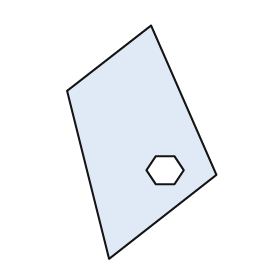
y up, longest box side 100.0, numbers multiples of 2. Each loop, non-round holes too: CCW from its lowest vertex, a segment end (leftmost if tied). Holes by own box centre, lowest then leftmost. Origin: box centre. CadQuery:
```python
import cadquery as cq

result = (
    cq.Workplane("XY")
    .moveTo(-14.0, -50.0)
    .lineTo(32.0, -14.0)
    .lineTo(4.0, 50.0)
    .lineTo(-32.0, 22.0)
    .close()
    .moveTo(6.0, -18.0)
    .lineTo(14.0, -18.0)
    .lineTo(18.0, -12.0)
    .lineTo(14.0, -6.0)
    .lineTo(6.0, -6.0)
    .lineTo(2.0, -12.0)
    .close()
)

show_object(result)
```